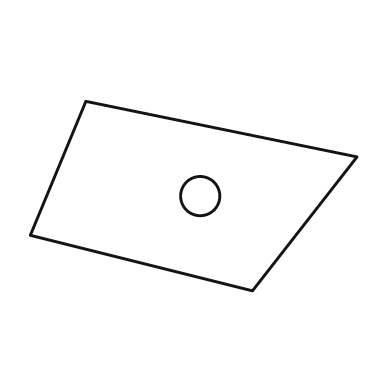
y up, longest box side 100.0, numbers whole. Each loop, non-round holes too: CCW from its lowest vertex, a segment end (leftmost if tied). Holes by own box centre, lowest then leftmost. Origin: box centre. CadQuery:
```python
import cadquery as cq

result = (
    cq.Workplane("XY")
    .moveTo(18.0, -29.0)
    .lineTo(50.0, 12.0)
    .lineTo(-33.0, 29.0)
    .lineTo(-50.0, -12.0)
    .close()
    .moveTo(2.0, 0.0)
    .circle(6.0)
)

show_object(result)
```